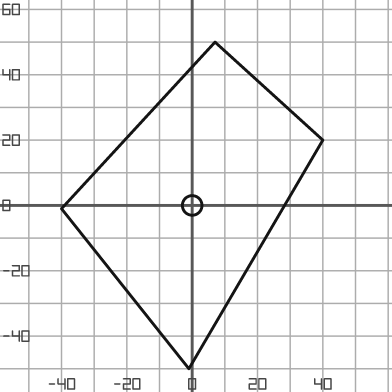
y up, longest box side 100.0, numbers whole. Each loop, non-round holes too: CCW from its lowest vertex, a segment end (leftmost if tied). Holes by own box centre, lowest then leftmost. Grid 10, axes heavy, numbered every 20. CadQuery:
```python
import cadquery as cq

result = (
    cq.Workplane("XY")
    .moveTo(-1.0, -50.0)
    .lineTo(40.0, 20.0)
    .lineTo(7.0, 50.0)
    .lineTo(-40.0, -1.0)
    .close()
    .moveTo(0.0, 0.0)
    .circle(3.0)
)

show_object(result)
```